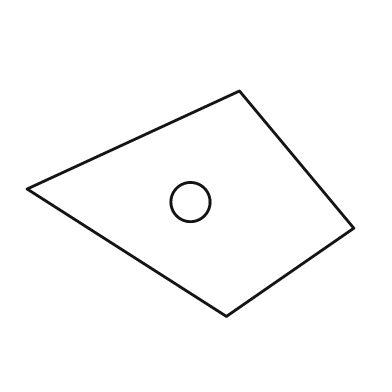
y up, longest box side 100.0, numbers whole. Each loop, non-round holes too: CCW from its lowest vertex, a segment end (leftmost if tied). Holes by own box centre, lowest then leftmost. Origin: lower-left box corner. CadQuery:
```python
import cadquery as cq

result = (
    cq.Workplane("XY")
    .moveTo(61.0, 0.0)
    .lineTo(100.0, 27.0)
    .lineTo(65.0, 69.0)
    .lineTo(0.0, 39.0)
    .close()
    .moveTo(50.0, 35.0)
    .circle(6.0)
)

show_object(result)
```